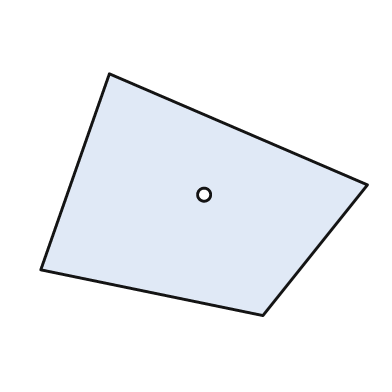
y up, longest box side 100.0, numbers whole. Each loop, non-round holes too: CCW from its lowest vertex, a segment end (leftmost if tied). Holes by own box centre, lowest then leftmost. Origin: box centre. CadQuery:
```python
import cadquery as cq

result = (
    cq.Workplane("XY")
    .moveTo(18.0, -37.0)
    .lineTo(50.0, 3.0)
    .lineTo(-29.0, 37.0)
    .lineTo(-50.0, -23.0)
    .close()
    .moveTo(0.0, 0.0)
    .circle(2.0)
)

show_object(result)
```